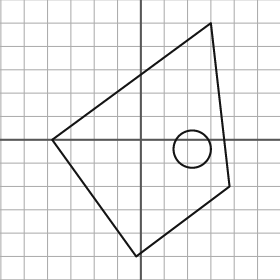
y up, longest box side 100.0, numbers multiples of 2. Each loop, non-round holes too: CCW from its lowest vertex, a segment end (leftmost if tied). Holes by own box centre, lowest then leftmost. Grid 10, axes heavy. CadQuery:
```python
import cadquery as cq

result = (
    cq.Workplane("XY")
    .moveTo(-2.0, -50.0)
    .lineTo(38.0, -20.0)
    .lineTo(30.0, 50.0)
    .lineTo(-38.0, 0.0)
    .close()
    .moveTo(22.0, -4.0)
    .circle(8.0)
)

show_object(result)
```